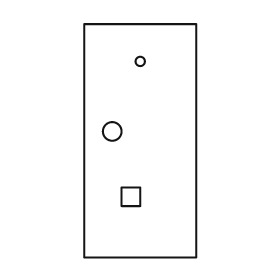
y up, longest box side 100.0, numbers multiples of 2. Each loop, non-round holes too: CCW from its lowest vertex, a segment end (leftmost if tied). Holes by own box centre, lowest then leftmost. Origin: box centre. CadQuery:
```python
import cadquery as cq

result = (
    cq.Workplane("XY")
    .moveTo(-24.0, -50.0)
    .lineTo(24.0, -50.0)
    .lineTo(24.0, 50.0)
    .lineTo(-24.0, 50.0)
    .close()
    .moveTo(-8.0, -28.0)
    .lineTo(0.0, -28.0)
    .lineTo(0.0, -20.0)
    .lineTo(-8.0, -20.0)
    .close()
    .moveTo(-12.0, 4.0)
    .circle(4.0)
    .moveTo(0.0, 34.0)
    .circle(2.0)
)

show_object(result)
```